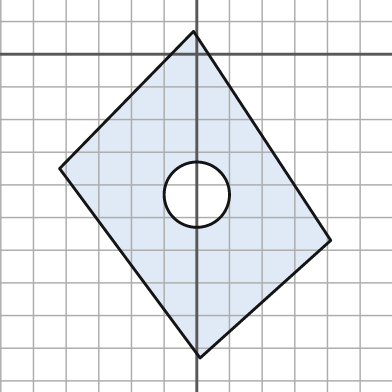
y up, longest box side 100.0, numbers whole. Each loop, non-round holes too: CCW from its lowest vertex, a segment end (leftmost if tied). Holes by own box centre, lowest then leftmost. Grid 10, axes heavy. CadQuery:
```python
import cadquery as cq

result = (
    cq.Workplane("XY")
    .moveTo(1.0, -93.0)
    .lineTo(41.0, -57.0)
    .lineTo(-1.0, 7.0)
    .lineTo(-42.0, -35.0)
    .close()
    .moveTo(0.0, -43.0)
    .circle(10.0)
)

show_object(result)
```